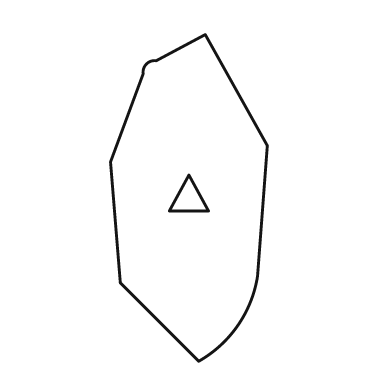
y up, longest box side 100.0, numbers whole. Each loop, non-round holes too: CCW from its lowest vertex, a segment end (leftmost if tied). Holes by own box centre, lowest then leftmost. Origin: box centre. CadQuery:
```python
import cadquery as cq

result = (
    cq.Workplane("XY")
    .moveTo(3.0, -50.0)
    .threePointArc((15.0, -39.0), (21.0, -24.0))
    .lineTo(24.0, 16.0)
    .lineTo(5.0, 50.0)
    .lineTo(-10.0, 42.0)
    .threePointArc((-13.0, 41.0), (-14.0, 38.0))
    .lineTo(-24.0, 11.0)
    .lineTo(-21.0, -26.0)
    .close()
    .moveTo(-6.0, -4.0)
    .lineTo(6.0, -4.0)
    .lineTo(0.0, 7.0)
    .close()
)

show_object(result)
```